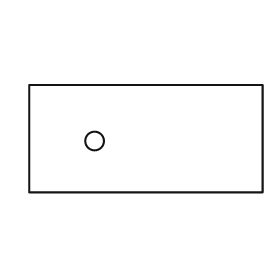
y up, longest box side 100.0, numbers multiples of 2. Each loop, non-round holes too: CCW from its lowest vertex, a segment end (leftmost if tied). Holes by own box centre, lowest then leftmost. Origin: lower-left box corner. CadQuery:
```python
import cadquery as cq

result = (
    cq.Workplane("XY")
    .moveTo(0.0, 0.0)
    .lineTo(100.0, 0.0)
    .lineTo(100.0, 46.0)
    .lineTo(0.0, 46.0)
    .close()
    .moveTo(28.0, 22.0)
    .circle(4.0)
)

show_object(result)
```